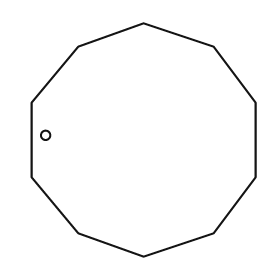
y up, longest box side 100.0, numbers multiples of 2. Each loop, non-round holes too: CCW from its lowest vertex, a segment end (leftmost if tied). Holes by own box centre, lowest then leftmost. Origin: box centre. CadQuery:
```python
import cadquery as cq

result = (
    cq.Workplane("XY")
    .moveTo(0.0, -50.0)
    .lineTo(30.0, -40.0)
    .lineTo(48.0, -16.0)
    .lineTo(48.0, 16.0)
    .lineTo(30.0, 40.0)
    .lineTo(0.0, 50.0)
    .lineTo(-28.0, 40.0)
    .lineTo(-48.0, 16.0)
    .lineTo(-48.0, -16.0)
    .lineTo(-28.0, -40.0)
    .close()
    .moveTo(-42.0, 2.0)
    .circle(2.0)
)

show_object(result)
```